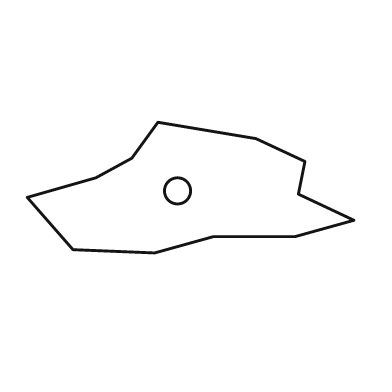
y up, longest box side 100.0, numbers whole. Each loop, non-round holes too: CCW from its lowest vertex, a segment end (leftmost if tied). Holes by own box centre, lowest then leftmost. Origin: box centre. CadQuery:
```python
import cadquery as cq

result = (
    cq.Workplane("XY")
    .moveTo(-11.0, -20.0)
    .lineTo(7.0, -15.0)
    .lineTo(32.0, -15.0)
    .lineTo(50.0, -10.0)
    .lineTo(33.0, -2.0)
    .lineTo(35.0, 8.0)
    .lineTo(20.0, 15.0)
    .lineTo(-10.0, 20.0)
    .lineTo(-18.0, 9.0)
    .lineTo(-29.0, 3.0)
    .lineTo(-50.0, -3.0)
    .lineTo(-36.0, -19.0)
    .close()
    .moveTo(-4.0, -1.0)
    .circle(4.0)
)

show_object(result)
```